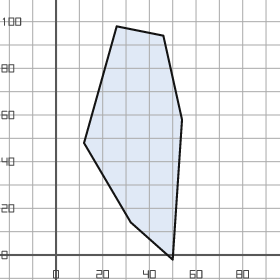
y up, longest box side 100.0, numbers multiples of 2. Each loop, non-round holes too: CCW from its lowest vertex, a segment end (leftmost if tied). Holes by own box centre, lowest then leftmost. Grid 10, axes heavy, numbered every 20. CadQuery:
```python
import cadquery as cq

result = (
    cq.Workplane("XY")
    .moveTo(50.0, -2.0)
    .lineTo(54.0, 58.0)
    .lineTo(46.0, 94.0)
    .lineTo(26.0, 98.0)
    .lineTo(12.0, 48.0)
    .lineTo(32.0, 14.0)
    .close()
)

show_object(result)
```